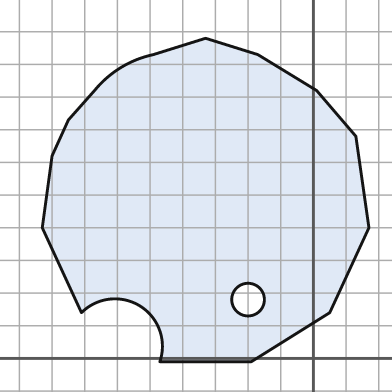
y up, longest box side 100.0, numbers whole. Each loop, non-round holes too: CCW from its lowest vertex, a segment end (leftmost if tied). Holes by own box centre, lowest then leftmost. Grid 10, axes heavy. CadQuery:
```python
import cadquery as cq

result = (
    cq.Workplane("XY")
    .moveTo(-47.0, -1.0)
    .lineTo(-19.0, -1.0)
    .lineTo(5.0, 14.0)
    .lineTo(17.0, 40.0)
    .lineTo(13.0, 68.0)
    .lineTo(1.0, 82.0)
    .lineTo(-17.0, 93.0)
    .lineTo(-33.0, 98.0)
    .lineTo(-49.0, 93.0)
    .threePointArc((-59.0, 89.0), (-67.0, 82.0))
    .lineTo(-75.0, 73.0)
    .lineTo(-80.0, 62.0)
    .lineTo(-83.0, 40.0)
    .lineTo(-71.0, 14.0)
    .threePointArc((-53.0, 16.0), (-47.0, -1.0))
    .close()
    .moveTo(-20.0, 18.0)
    .circle(5.0)
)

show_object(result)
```